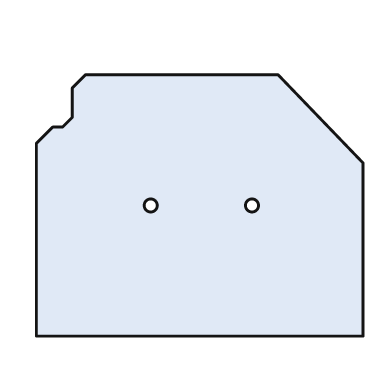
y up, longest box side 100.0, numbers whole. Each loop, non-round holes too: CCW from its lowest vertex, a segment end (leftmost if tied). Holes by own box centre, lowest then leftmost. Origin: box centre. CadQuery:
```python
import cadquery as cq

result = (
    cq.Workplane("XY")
    .moveTo(-50.0, -40.0)
    .lineTo(50.0, -40.0)
    .lineTo(50.0, 13.0)
    .lineTo(24.0, 40.0)
    .lineTo(-35.0, 40.0)
    .lineTo(-39.0, 36.0)
    .lineTo(-39.0, 27.0)
    .lineTo(-42.0, 24.0)
    .lineTo(-45.0, 24.0)
    .lineTo(-50.0, 19.0)
    .close()
    .moveTo(-15.0, 0.0)
    .circle(2.0)
    .moveTo(16.0, 0.0)
    .circle(2.0)
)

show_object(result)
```